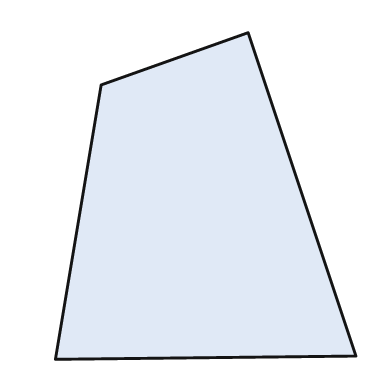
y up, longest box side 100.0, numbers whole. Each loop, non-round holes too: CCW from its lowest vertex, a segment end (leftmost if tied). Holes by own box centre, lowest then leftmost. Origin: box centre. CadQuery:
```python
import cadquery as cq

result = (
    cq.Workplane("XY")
    .moveTo(-46.0, -50.0)
    .lineTo(46.0, -49.0)
    .lineTo(13.0, 50.0)
    .lineTo(-32.0, 34.0)
    .close()
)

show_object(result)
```